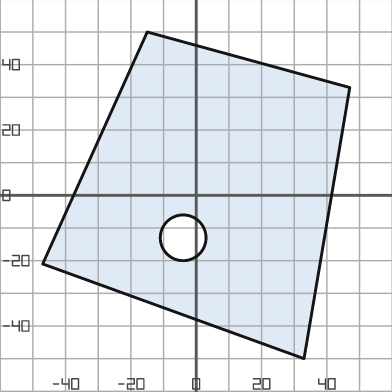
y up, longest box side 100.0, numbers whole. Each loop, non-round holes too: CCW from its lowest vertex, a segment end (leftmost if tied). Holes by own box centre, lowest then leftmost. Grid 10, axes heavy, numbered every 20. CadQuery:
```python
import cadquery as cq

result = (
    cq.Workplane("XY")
    .moveTo(33.0, -50.0)
    .lineTo(47.0, 33.0)
    .lineTo(-15.0, 50.0)
    .lineTo(-47.0, -21.0)
    .close()
    .moveTo(-4.0, -13.0)
    .circle(7.0)
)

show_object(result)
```